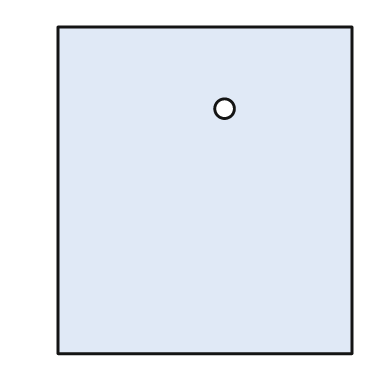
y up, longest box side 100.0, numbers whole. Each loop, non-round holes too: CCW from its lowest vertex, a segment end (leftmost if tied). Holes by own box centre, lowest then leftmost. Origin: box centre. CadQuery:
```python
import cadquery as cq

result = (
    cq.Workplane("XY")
    .moveTo(-45.0, -50.0)
    .lineTo(45.0, -50.0)
    .lineTo(45.0, 50.0)
    .lineTo(-45.0, 50.0)
    .close()
    .moveTo(6.0, 25.0)
    .circle(3.0)
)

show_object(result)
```